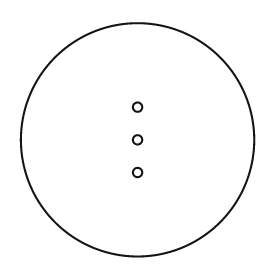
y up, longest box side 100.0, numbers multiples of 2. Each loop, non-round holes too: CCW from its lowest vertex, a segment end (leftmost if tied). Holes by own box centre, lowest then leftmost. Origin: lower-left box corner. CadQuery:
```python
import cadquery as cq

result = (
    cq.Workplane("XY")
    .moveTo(50.0, 50.0)
    .circle(50.0)
    .moveTo(50.0, 36.0)
    .circle(2.0)
    .moveTo(50.0, 50.0)
    .circle(2.0)
    .moveTo(50.0, 64.0)
    .circle(2.0)
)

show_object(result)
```